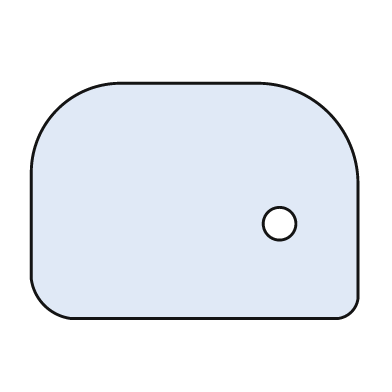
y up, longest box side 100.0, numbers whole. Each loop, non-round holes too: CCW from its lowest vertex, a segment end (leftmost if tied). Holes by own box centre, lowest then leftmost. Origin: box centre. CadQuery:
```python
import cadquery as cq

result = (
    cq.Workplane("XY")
    .moveTo(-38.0, -36.0)
    .lineTo(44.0, -36.0)
    .threePointArc((48.0, -34.0), (50.0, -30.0))
    .lineTo(50.0, 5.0)
    .threePointArc((41.0, 27.0), (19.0, 36.0))
    .lineTo(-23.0, 36.0)
    .threePointArc((-42.0, 28.0), (-50.0, 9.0))
    .lineTo(-50.0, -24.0)
    .threePointArc((-46.0, -32.0), (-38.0, -36.0))
    .close()
    .moveTo(26.0, -7.0)
    .circle(5.0)
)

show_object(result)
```